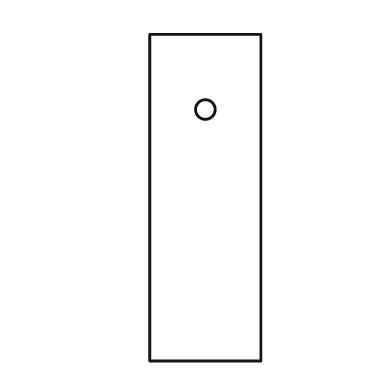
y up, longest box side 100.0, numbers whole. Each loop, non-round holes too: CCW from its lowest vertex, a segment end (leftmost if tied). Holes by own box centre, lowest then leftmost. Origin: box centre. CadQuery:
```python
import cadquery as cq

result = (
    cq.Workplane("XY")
    .moveTo(-17.0, -50.0)
    .lineTo(17.0, -50.0)
    .lineTo(17.0, 50.0)
    .lineTo(-17.0, 50.0)
    .close()
    .moveTo(0.0, 27.0)
    .circle(3.0)
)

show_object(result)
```